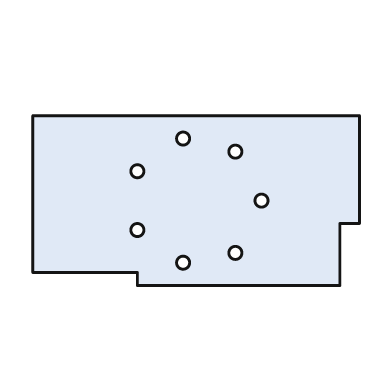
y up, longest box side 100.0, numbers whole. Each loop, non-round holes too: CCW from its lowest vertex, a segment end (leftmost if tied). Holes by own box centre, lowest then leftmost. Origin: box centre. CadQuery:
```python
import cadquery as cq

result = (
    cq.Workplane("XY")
    .moveTo(-18.0, -26.0)
    .lineTo(44.0, -26.0)
    .lineTo(44.0, -7.0)
    .lineTo(50.0, -7.0)
    .lineTo(50.0, 26.0)
    .lineTo(-50.0, 26.0)
    .lineTo(-50.0, -22.0)
    .lineTo(-18.0, -22.0)
    .close()
    .moveTo(-4.0, -19.0)
    .circle(2.0)
    .moveTo(12.0, -16.0)
    .circle(2.0)
    .moveTo(-18.0, -9.0)
    .circle(2.0)
    .moveTo(20.0, 0.0)
    .circle(2.0)
    .moveTo(-18.0, 9.0)
    .circle(2.0)
    .moveTo(12.0, 15.0)
    .circle(2.0)
    .moveTo(-4.0, 19.0)
    .circle(2.0)
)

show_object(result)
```